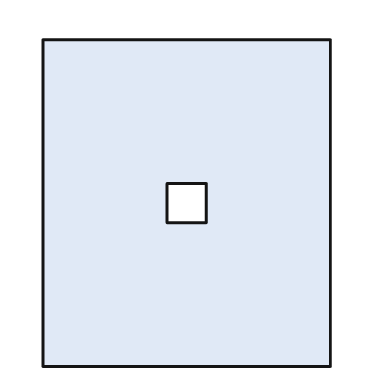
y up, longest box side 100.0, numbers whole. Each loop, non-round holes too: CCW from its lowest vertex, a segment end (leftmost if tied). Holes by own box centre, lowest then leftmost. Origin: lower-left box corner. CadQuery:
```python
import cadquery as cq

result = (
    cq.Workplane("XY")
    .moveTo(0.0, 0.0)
    .lineTo(88.0, 0.0)
    .lineTo(88.0, 100.0)
    .lineTo(0.0, 100.0)
    .close()
    .moveTo(38.0, 44.0)
    .lineTo(50.0, 44.0)
    .lineTo(50.0, 56.0)
    .lineTo(38.0, 56.0)
    .close()
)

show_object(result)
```